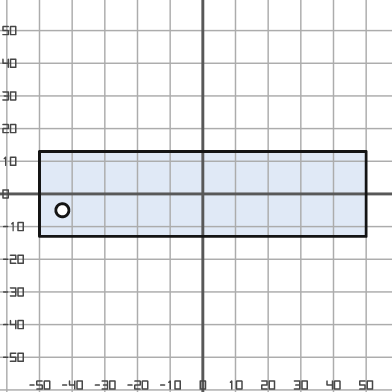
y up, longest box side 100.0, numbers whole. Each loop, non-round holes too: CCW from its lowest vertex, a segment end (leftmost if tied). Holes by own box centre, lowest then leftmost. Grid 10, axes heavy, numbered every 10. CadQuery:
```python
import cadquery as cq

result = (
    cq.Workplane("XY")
    .moveTo(-50.0, -13.0)
    .lineTo(50.0, -13.0)
    .lineTo(50.0, 13.0)
    .lineTo(-50.0, 13.0)
    .close()
    .moveTo(-43.0, -5.0)
    .circle(2.0)
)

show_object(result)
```